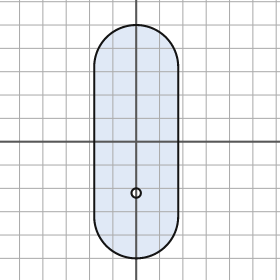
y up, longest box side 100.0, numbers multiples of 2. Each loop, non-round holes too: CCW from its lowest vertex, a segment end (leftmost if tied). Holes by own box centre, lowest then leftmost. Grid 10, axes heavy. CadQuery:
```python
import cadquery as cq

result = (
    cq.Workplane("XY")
    .moveTo(-18.0, -32.0)
    .threePointArc((0.0, -50.0), (18.0, -32.0))
    .lineTo(18.0, 32.0)
    .threePointArc((0.0, 50.0), (-18.0, 32.0))
    .close()
    .moveTo(0.0, -22.0)
    .circle(2.0)
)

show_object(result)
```